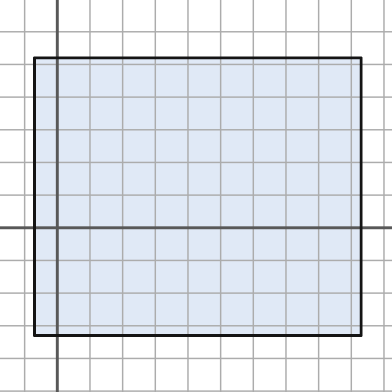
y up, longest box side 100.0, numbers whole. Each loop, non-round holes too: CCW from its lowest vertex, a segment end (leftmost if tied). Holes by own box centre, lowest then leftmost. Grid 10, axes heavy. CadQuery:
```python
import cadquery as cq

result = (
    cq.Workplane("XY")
    .moveTo(-7.0, -33.0)
    .lineTo(93.0, -33.0)
    .lineTo(93.0, 52.0)
    .lineTo(-7.0, 52.0)
    .close()
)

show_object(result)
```